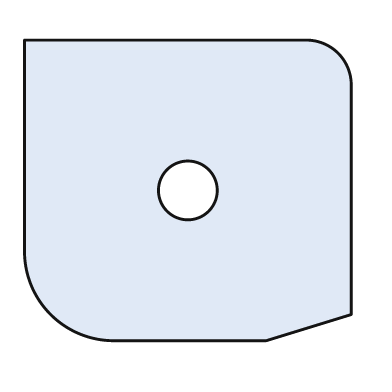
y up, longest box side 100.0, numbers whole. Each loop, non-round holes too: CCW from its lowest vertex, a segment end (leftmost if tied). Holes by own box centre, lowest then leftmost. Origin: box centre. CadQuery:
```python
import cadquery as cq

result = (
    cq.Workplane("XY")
    .moveTo(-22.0, -46.0)
    .lineTo(24.0, -46.0)
    .lineTo(50.0, -38.0)
    .lineTo(50.0, 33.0)
    .threePointArc((46.0, 42.0), (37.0, 46.0))
    .lineTo(-50.0, 46.0)
    .lineTo(-50.0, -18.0)
    .threePointArc((-42.0, -38.0), (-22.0, -46.0))
    .close()
    .moveTo(0.0, 0.0)
    .circle(9.0)
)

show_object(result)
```